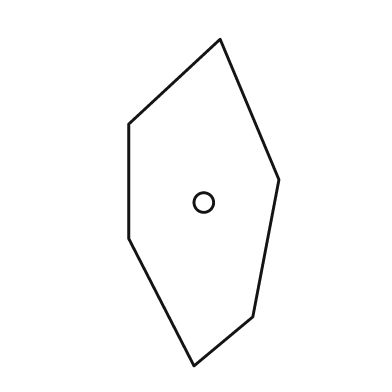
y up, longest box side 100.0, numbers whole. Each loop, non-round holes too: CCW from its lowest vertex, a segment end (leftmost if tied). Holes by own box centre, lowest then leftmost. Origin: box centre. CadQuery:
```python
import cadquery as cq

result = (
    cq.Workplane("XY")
    .moveTo(-3.0, -50.0)
    .lineTo(15.0, -35.0)
    .lineTo(23.0, 7.0)
    .lineTo(5.0, 50.0)
    .lineTo(-23.0, 24.0)
    .lineTo(-23.0, -11.0)
    .close()
    .moveTo(0.0, 0.0)
    .circle(3.0)
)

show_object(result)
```